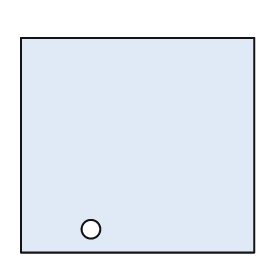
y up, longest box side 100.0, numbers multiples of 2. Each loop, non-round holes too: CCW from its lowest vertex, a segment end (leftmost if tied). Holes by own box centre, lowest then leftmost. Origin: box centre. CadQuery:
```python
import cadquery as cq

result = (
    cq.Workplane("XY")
    .moveTo(-50.0, -46.0)
    .lineTo(50.0, -46.0)
    .lineTo(50.0, 46.0)
    .lineTo(-50.0, 46.0)
    .close()
    .moveTo(-20.0, -36.0)
    .circle(4.0)
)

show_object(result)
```